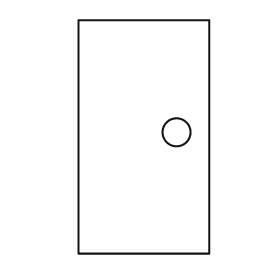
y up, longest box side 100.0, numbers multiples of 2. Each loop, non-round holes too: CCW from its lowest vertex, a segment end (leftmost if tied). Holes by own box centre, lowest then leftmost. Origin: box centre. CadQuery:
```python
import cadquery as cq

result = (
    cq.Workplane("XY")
    .moveTo(-28.0, -50.0)
    .lineTo(28.0, -50.0)
    .lineTo(28.0, 50.0)
    .lineTo(-28.0, 50.0)
    .close()
    .moveTo(14.0, 2.0)
    .circle(6.0)
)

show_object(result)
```